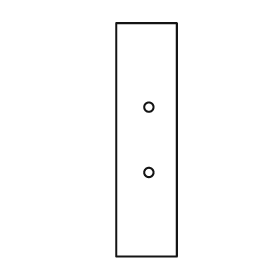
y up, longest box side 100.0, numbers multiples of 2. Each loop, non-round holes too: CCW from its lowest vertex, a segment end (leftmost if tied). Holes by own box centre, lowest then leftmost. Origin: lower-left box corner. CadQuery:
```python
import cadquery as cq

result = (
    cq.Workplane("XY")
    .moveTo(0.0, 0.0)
    .lineTo(26.0, 0.0)
    .lineTo(26.0, 100.0)
    .lineTo(0.0, 100.0)
    .close()
    .moveTo(14.0, 36.0)
    .circle(2.0)
    .moveTo(14.0, 64.0)
    .circle(2.0)
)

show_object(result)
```